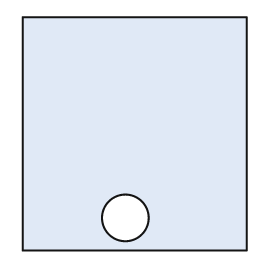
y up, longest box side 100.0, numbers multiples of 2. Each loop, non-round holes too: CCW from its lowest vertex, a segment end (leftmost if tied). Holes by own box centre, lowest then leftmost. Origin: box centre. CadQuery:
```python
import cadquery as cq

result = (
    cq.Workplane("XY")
    .moveTo(-48.0, -50.0)
    .lineTo(48.0, -50.0)
    .lineTo(48.0, 50.0)
    .lineTo(-48.0, 50.0)
    .close()
    .moveTo(-4.0, -36.0)
    .circle(10.0)
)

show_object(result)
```